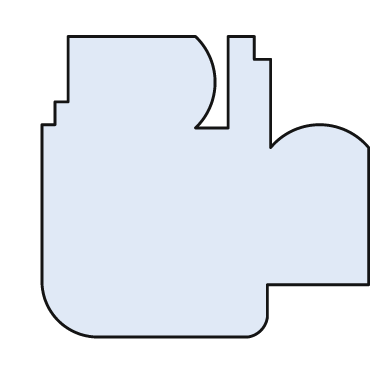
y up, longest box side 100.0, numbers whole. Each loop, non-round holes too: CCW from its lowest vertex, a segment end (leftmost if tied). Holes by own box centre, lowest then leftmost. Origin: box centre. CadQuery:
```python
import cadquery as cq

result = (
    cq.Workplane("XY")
    .moveTo(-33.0, -46.0)
    .lineTo(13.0, -46.0)
    .threePointArc((17.0, -44.0), (19.0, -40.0))
    .lineTo(19.0, -30.0)
    .lineTo(50.0, -30.0)
    .lineTo(50.0, 12.0)
    .threePointArc((35.0, 19.0), (20.0, 12.0))
    .lineTo(20.0, 39.0)
    .lineTo(15.0, 39.0)
    .lineTo(15.0, 46.0)
    .lineTo(7.0, 46.0)
    .lineTo(7.0, 18.0)
    .lineTo(-3.0, 18.0)
    .threePointArc((3.0, 32.0), (-3.0, 46.0))
    .lineTo(-42.0, 46.0)
    .lineTo(-42.0, 26.0)
    .lineTo(-46.0, 26.0)
    .lineTo(-46.0, 19.0)
    .lineTo(-50.0, 19.0)
    .lineTo(-50.0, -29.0)
    .threePointArc((-45.0, -41.0), (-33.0, -46.0))
    .close()
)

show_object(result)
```